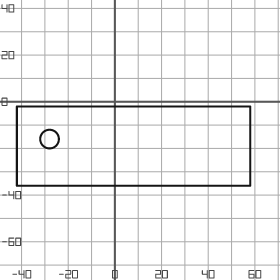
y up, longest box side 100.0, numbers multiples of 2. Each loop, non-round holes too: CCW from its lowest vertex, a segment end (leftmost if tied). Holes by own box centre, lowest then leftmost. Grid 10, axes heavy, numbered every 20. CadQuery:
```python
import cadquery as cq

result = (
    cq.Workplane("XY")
    .moveTo(-42.0, -36.0)
    .lineTo(58.0, -36.0)
    .lineTo(58.0, -2.0)
    .lineTo(-42.0, -2.0)
    .close()
    .moveTo(-28.0, -16.0)
    .circle(4.0)
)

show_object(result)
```